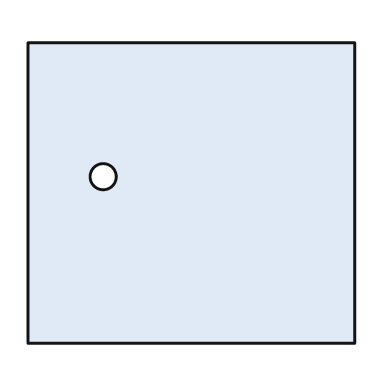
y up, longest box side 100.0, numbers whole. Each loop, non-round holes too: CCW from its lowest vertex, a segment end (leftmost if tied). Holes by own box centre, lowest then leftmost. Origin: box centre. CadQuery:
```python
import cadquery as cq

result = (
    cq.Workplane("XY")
    .moveTo(-50.0, -46.0)
    .lineTo(50.0, -46.0)
    .lineTo(50.0, 46.0)
    .lineTo(-50.0, 46.0)
    .close()
    .moveTo(-27.0, 5.0)
    .circle(4.0)
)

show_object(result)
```